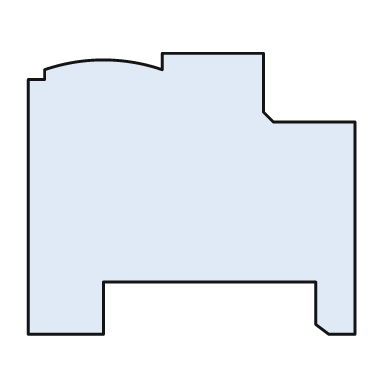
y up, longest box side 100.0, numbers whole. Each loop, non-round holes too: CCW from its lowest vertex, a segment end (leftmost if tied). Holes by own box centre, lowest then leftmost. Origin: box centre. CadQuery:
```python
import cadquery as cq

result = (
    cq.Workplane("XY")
    .moveTo(-50.0, -43.0)
    .lineTo(-27.0, -43.0)
    .lineTo(-27.0, -27.0)
    .lineTo(38.0, -27.0)
    .lineTo(38.0, -40.0)
    .lineTo(42.0, -43.0)
    .lineTo(50.0, -43.0)
    .lineTo(50.0, 22.0)
    .lineTo(25.0, 22.0)
    .lineTo(22.0, 25.0)
    .lineTo(22.0, 43.0)
    .lineTo(-9.0, 43.0)
    .lineTo(-9.0, 38.0)
    .threePointArc((-27.0, 41.0), (-45.0, 38.0))
    .lineTo(-45.0, 35.0)
    .lineTo(-50.0, 35.0)
    .close()
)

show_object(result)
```